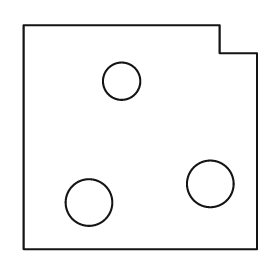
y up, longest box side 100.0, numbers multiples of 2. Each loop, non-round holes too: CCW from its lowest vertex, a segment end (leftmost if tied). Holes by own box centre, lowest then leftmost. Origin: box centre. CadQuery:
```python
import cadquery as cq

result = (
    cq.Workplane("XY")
    .moveTo(-50.0, -48.0)
    .lineTo(50.0, -48.0)
    .lineTo(50.0, 36.0)
    .lineTo(34.0, 36.0)
    .lineTo(34.0, 48.0)
    .lineTo(-50.0, 48.0)
    .close()
    .moveTo(-22.0, -28.0)
    .circle(10.0)
    .moveTo(30.0, -20.0)
    .circle(10.0)
    .moveTo(-8.0, 24.0)
    .circle(8.0)
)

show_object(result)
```